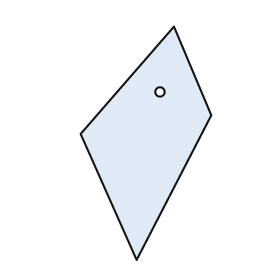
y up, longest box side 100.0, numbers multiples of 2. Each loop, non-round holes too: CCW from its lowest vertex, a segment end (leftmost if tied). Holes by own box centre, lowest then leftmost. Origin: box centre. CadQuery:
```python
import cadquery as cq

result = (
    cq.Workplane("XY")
    .moveTo(-4.0, -50.0)
    .lineTo(28.0, 12.0)
    .lineTo(12.0, 50.0)
    .lineTo(-28.0, 4.0)
    .close()
    .moveTo(6.0, 22.0)
    .circle(2.0)
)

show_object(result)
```